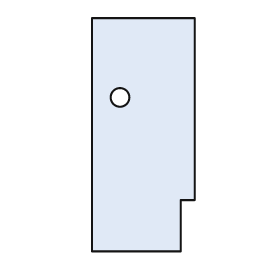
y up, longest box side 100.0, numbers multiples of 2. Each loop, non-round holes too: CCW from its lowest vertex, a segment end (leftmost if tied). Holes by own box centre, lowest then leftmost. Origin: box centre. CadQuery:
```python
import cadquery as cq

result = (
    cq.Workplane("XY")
    .moveTo(-22.0, -50.0)
    .lineTo(16.0, -50.0)
    .lineTo(16.0, -28.0)
    .lineTo(22.0, -28.0)
    .lineTo(22.0, 50.0)
    .lineTo(-22.0, 50.0)
    .close()
    .moveTo(-10.0, 16.0)
    .circle(4.0)
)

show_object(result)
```